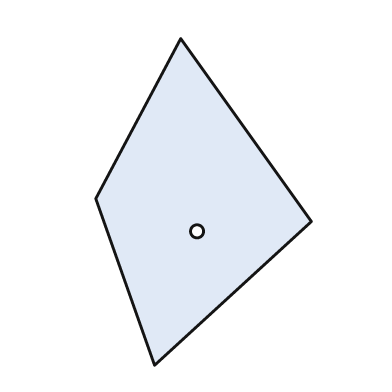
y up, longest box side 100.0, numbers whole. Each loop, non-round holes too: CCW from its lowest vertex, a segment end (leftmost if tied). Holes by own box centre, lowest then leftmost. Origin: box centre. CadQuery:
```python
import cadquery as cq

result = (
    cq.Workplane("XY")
    .moveTo(-15.0, -50.0)
    .lineTo(33.0, -6.0)
    .lineTo(-7.0, 50.0)
    .lineTo(-33.0, 1.0)
    .close()
    .moveTo(-2.0, -9.0)
    .circle(2.0)
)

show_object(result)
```